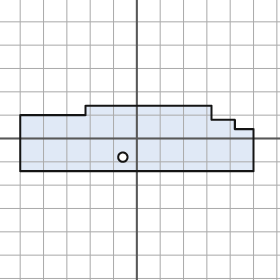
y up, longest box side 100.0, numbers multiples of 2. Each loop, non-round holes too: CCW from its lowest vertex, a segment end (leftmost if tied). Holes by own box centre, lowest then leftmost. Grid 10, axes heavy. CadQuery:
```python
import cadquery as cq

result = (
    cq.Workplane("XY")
    .moveTo(-50.0, -14.0)
    .lineTo(50.0, -14.0)
    .lineTo(50.0, 4.0)
    .lineTo(42.0, 4.0)
    .lineTo(42.0, 8.0)
    .lineTo(32.0, 8.0)
    .lineTo(32.0, 14.0)
    .lineTo(-22.0, 14.0)
    .lineTo(-22.0, 10.0)
    .lineTo(-50.0, 10.0)
    .close()
    .moveTo(-6.0, -8.0)
    .circle(2.0)
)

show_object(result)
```